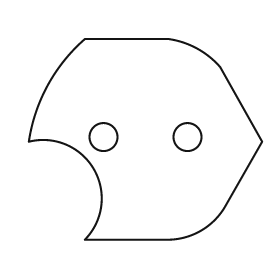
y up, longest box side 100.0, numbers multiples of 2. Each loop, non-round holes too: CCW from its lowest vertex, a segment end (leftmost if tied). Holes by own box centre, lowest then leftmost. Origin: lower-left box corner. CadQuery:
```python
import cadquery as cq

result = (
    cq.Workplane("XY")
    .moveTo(24.0, 0.0)
    .lineTo(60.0, 0.0)
    .threePointArc((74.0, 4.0), (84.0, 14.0))
    .lineTo(100.0, 42.0)
    .lineTo(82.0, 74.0)
    .threePointArc((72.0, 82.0), (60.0, 86.0))
    .lineTo(24.0, 86.0)
    .threePointArc((8.0, 66.0), (0.0, 42.0))
    .threePointArc((28.0, 30.0), (24.0, 0.0))
    .close()
    .moveTo(32.0, 44.0)
    .circle(6.0)
    .moveTo(68.0, 44.0)
    .circle(6.0)
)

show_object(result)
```